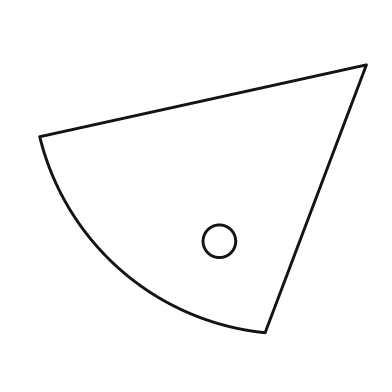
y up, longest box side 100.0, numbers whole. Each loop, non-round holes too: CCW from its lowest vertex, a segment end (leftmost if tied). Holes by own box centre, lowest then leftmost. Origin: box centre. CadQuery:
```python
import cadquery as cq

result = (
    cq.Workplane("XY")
    .moveTo(19.0, -41.0)
    .lineTo(50.0, 41.0)
    .lineTo(-50.0, 19.0)
    .threePointArc((-25.0, -22.0), (19.0, -41.0))
    .close()
    .moveTo(5.0, -13.0)
    .circle(5.0)
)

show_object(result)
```